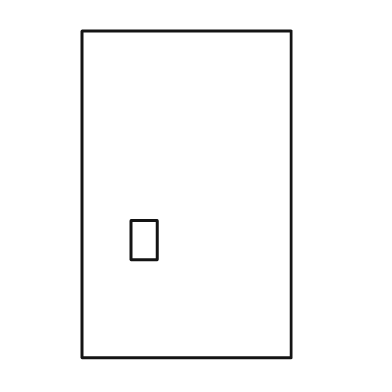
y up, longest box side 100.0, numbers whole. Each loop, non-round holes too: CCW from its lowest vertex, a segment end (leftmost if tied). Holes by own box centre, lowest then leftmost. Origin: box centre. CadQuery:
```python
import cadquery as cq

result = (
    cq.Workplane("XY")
    .moveTo(-32.0, -50.0)
    .lineTo(32.0, -50.0)
    .lineTo(32.0, 50.0)
    .lineTo(-32.0, 50.0)
    .close()
    .moveTo(-17.0, -20.0)
    .lineTo(-9.0, -20.0)
    .lineTo(-9.0, -8.0)
    .lineTo(-17.0, -8.0)
    .close()
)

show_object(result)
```